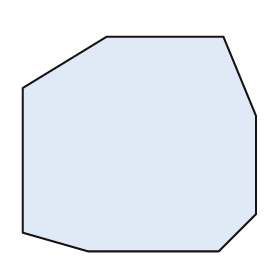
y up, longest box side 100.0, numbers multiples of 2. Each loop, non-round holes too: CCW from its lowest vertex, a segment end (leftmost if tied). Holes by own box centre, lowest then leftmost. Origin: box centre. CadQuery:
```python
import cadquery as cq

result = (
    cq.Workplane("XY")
    .moveTo(-22.0, -46.0)
    .lineTo(34.0, -46.0)
    .lineTo(50.0, -30.0)
    .lineTo(50.0, 12.0)
    .lineTo(36.0, 46.0)
    .lineTo(-14.0, 46.0)
    .lineTo(-50.0, 24.0)
    .lineTo(-50.0, -38.0)
    .close()
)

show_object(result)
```